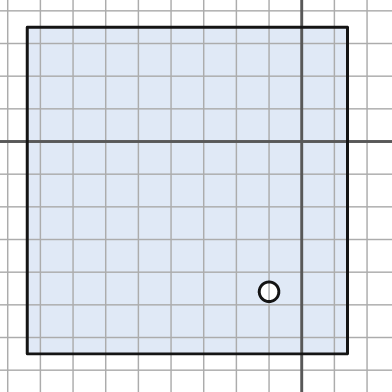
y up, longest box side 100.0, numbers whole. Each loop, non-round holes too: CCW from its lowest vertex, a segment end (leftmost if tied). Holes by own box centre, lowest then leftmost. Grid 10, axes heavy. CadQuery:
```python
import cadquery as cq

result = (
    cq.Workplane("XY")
    .moveTo(-84.0, -65.0)
    .lineTo(14.0, -65.0)
    .lineTo(14.0, 35.0)
    .lineTo(-84.0, 35.0)
    .close()
    .moveTo(-10.0, -46.0)
    .circle(3.0)
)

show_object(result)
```